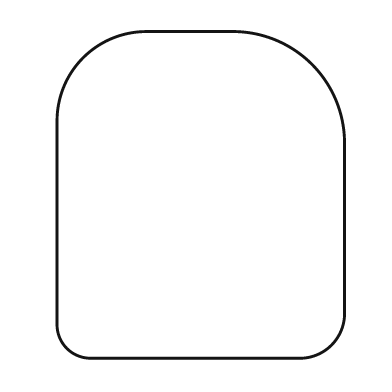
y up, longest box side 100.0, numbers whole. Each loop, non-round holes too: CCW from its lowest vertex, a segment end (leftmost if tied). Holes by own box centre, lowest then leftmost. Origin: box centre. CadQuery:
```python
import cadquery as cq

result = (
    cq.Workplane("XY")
    .moveTo(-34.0, -50.0)
    .lineTo(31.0, -50.0)
    .threePointArc((40.0, -46.0), (44.0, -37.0))
    .lineTo(44.0, 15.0)
    .threePointArc((34.0, 40.0), (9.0, 50.0))
    .lineTo(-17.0, 50.0)
    .threePointArc((-36.0, 42.0), (-44.0, 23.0))
    .lineTo(-44.0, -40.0)
    .threePointArc((-41.0, -47.0), (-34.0, -50.0))
    .close()
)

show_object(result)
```